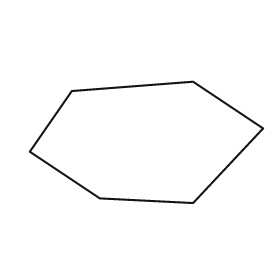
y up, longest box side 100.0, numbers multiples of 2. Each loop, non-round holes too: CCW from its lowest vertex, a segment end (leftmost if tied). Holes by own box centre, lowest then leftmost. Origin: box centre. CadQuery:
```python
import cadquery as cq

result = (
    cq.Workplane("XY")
    .moveTo(20.0, -26.0)
    .lineTo(50.0, 6.0)
    .lineTo(20.0, 26.0)
    .lineTo(-32.0, 22.0)
    .lineTo(-50.0, -4.0)
    .lineTo(-20.0, -24.0)
    .close()
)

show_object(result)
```